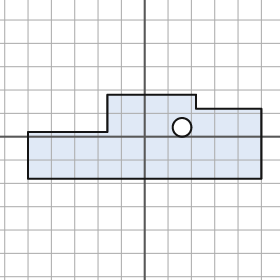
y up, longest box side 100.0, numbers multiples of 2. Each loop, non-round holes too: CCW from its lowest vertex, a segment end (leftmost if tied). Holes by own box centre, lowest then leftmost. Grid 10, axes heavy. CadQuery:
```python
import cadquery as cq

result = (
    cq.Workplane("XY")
    .moveTo(-50.0, -18.0)
    .lineTo(50.0, -18.0)
    .lineTo(50.0, 12.0)
    .lineTo(22.0, 12.0)
    .lineTo(22.0, 18.0)
    .lineTo(-16.0, 18.0)
    .lineTo(-16.0, 2.0)
    .lineTo(-50.0, 2.0)
    .close()
    .moveTo(16.0, 4.0)
    .circle(4.0)
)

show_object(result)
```